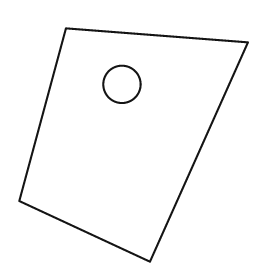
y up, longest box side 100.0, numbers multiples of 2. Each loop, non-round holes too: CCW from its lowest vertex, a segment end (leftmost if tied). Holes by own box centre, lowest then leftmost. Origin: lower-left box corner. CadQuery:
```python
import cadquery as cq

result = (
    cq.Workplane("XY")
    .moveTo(56.0, 0.0)
    .lineTo(98.0, 94.0)
    .lineTo(20.0, 100.0)
    .lineTo(0.0, 26.0)
    .close()
    .moveTo(44.0, 76.0)
    .circle(8.0)
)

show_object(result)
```